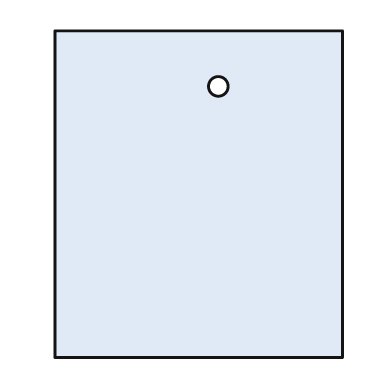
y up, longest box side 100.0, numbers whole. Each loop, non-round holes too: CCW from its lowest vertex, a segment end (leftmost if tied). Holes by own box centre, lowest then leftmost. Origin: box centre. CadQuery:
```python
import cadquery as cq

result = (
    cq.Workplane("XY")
    .moveTo(-44.0, -50.0)
    .lineTo(44.0, -50.0)
    .lineTo(44.0, 50.0)
    .lineTo(-44.0, 50.0)
    .close()
    .moveTo(6.0, 33.0)
    .circle(3.0)
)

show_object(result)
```